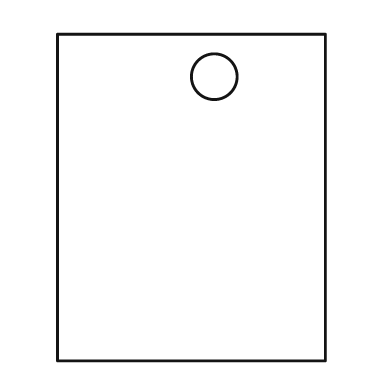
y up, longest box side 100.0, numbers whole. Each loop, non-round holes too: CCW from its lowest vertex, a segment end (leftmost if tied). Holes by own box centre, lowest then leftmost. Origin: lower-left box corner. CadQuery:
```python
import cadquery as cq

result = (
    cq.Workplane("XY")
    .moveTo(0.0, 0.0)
    .lineTo(82.0, 0.0)
    .lineTo(82.0, 100.0)
    .lineTo(0.0, 100.0)
    .close()
    .moveTo(48.0, 87.0)
    .circle(7.0)
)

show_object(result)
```